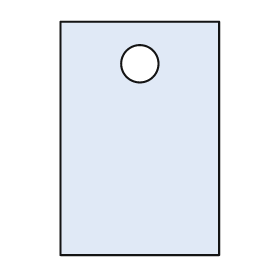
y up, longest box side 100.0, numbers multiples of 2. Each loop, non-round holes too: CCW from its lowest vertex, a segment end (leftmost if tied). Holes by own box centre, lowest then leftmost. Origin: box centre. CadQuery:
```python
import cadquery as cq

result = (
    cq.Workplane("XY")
    .moveTo(-34.0, -50.0)
    .lineTo(34.0, -50.0)
    .lineTo(34.0, 50.0)
    .lineTo(-34.0, 50.0)
    .close()
    .moveTo(0.0, 32.0)
    .circle(8.0)
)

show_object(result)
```